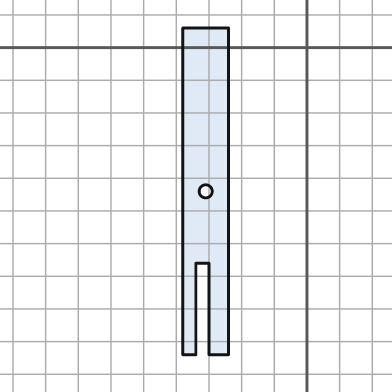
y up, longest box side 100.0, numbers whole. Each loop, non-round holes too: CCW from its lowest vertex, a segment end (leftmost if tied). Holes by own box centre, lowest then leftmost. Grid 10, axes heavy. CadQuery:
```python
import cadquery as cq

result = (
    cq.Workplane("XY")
    .moveTo(-38.0, -94.0)
    .lineTo(-34.0, -94.0)
    .lineTo(-34.0, -66.0)
    .lineTo(-30.0, -66.0)
    .lineTo(-30.0, -94.0)
    .lineTo(-24.0, -94.0)
    .lineTo(-24.0, 6.0)
    .lineTo(-38.0, 6.0)
    .close()
    .moveTo(-31.0, -44.0)
    .circle(2.0)
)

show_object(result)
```